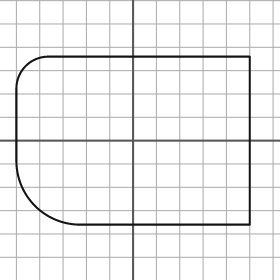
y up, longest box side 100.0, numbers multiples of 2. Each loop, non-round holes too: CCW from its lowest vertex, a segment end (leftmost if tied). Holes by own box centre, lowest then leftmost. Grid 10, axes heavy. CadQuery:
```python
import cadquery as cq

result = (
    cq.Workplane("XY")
    .moveTo(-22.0, -36.0)
    .lineTo(50.0, -36.0)
    .lineTo(50.0, 36.0)
    .lineTo(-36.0, 36.0)
    .threePointArc((-46.0, 32.0), (-50.0, 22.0))
    .lineTo(-50.0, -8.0)
    .threePointArc((-42.0, -28.0), (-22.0, -36.0))
    .close()
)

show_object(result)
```